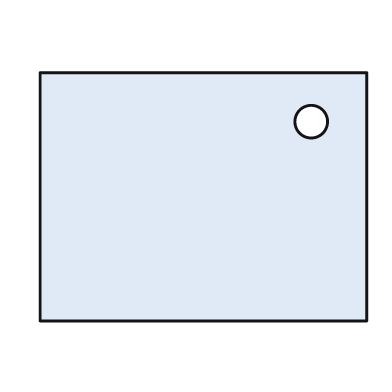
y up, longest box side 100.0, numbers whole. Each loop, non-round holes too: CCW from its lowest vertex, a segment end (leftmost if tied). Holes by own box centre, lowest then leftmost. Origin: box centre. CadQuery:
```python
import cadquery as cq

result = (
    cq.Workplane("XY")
    .moveTo(-50.0, -38.0)
    .lineTo(50.0, -38.0)
    .lineTo(50.0, 38.0)
    .lineTo(-50.0, 38.0)
    .close()
    .moveTo(33.0, 23.0)
    .circle(5.0)
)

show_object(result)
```